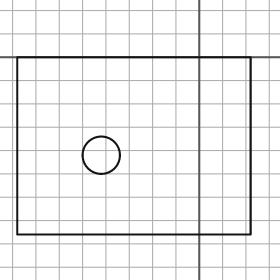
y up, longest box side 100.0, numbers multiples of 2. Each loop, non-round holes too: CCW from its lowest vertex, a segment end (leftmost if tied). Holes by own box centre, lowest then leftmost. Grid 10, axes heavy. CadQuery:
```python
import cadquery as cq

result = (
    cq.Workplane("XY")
    .moveTo(-78.0, -76.0)
    .lineTo(22.0, -76.0)
    .lineTo(22.0, 0.0)
    .lineTo(-78.0, 0.0)
    .close()
    .moveTo(-42.0, -42.0)
    .circle(8.0)
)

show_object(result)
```